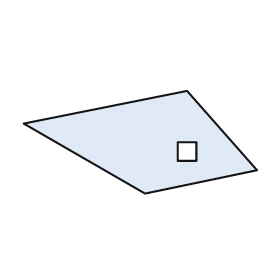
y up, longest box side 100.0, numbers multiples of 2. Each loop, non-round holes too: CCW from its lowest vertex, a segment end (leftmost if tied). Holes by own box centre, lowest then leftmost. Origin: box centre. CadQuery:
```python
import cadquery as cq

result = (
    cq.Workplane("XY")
    .moveTo(2.0, -22.0)
    .lineTo(50.0, -12.0)
    .lineTo(20.0, 22.0)
    .lineTo(-50.0, 8.0)
    .close()
    .moveTo(16.0, -8.0)
    .lineTo(24.0, -8.0)
    .lineTo(24.0, 0.0)
    .lineTo(16.0, 0.0)
    .close()
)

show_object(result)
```